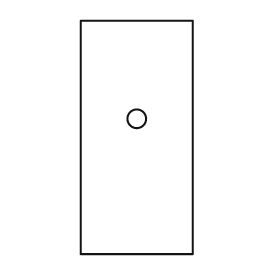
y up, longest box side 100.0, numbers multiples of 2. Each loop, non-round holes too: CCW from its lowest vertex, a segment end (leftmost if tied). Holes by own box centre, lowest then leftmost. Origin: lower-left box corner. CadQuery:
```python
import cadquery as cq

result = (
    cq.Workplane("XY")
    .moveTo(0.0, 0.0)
    .lineTo(48.0, 0.0)
    .lineTo(48.0, 100.0)
    .lineTo(0.0, 100.0)
    .close()
    .moveTo(24.0, 58.0)
    .circle(4.0)
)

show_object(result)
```